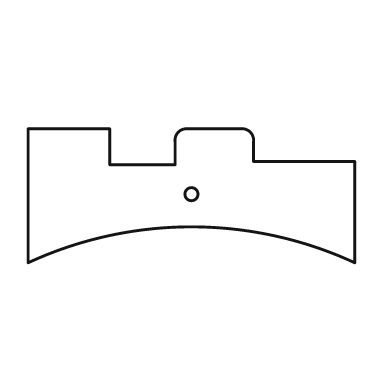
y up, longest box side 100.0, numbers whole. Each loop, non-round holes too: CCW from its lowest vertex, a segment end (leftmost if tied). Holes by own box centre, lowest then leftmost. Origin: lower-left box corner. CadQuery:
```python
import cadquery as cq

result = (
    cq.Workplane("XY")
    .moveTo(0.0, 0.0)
    .threePointArc((50.0, 11.0), (100.0, 0.0))
    .lineTo(100.0, 31.0)
    .lineTo(69.0, 31.0)
    .lineTo(69.0, 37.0)
    .threePointArc((68.0, 40.0), (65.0, 41.0))
    .lineTo(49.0, 41.0)
    .threePointArc((46.0, 40.0), (45.0, 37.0))
    .lineTo(45.0, 30.0)
    .lineTo(25.0, 30.0)
    .lineTo(25.0, 41.0)
    .lineTo(0.0, 41.0)
    .close()
    .moveTo(50.0, 21.0)
    .circle(2.0)
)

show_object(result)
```